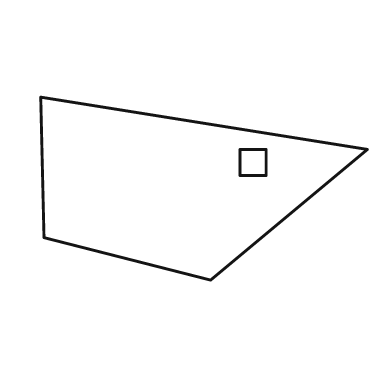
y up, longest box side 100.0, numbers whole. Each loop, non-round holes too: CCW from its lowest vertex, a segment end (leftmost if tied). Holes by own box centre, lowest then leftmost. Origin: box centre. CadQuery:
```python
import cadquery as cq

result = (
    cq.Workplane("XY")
    .moveTo(2.0, -28.0)
    .lineTo(50.0, 12.0)
    .lineTo(-50.0, 28.0)
    .lineTo(-49.0, -15.0)
    .close()
    .moveTo(11.0, 4.0)
    .lineTo(19.0, 4.0)
    .lineTo(19.0, 12.0)
    .lineTo(11.0, 12.0)
    .close()
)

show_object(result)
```